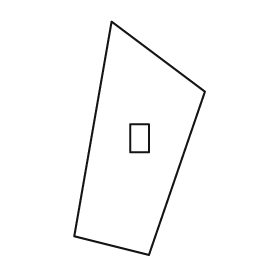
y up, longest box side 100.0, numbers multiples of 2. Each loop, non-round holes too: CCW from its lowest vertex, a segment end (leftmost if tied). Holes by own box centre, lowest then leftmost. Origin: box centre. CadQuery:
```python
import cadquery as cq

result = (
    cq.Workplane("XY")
    .moveTo(4.0, -50.0)
    .lineTo(28.0, 20.0)
    .lineTo(-12.0, 50.0)
    .lineTo(-28.0, -42.0)
    .close()
    .moveTo(-4.0, -6.0)
    .lineTo(4.0, -6.0)
    .lineTo(4.0, 6.0)
    .lineTo(-4.0, 6.0)
    .close()
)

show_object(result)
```